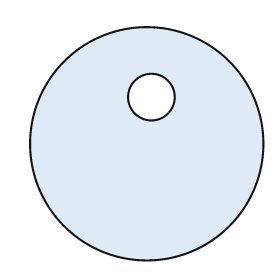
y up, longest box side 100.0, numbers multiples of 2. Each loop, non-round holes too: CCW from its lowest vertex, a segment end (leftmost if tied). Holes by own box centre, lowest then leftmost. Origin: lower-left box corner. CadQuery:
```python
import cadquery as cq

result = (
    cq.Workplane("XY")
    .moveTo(50.0, 50.0)
    .circle(50.0)
    .moveTo(52.0, 70.0)
    .circle(10.0)
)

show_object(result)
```